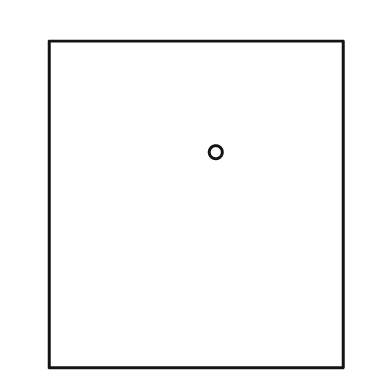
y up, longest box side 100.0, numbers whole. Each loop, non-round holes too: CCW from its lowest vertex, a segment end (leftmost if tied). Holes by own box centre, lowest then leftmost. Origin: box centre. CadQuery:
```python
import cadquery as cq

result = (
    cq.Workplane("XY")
    .moveTo(-45.0, -50.0)
    .lineTo(45.0, -50.0)
    .lineTo(45.0, 50.0)
    .lineTo(-45.0, 50.0)
    .close()
    .moveTo(6.0, 16.0)
    .circle(2.0)
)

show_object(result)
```